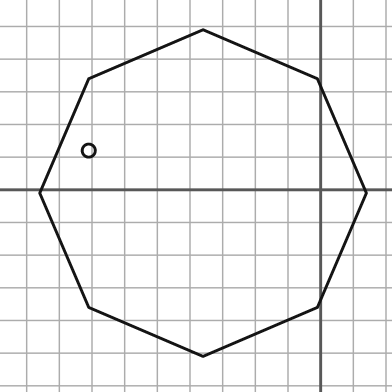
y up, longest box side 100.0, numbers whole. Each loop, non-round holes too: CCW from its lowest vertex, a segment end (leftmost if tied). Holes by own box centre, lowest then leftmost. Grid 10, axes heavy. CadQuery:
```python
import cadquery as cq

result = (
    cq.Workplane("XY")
    .moveTo(-36.0, -51.0)
    .lineTo(-1.0, -36.0)
    .lineTo(14.0, -1.0)
    .lineTo(-1.0, 34.0)
    .lineTo(-36.0, 49.0)
    .lineTo(-71.0, 34.0)
    .lineTo(-86.0, -1.0)
    .lineTo(-71.0, -36.0)
    .close()
    .moveTo(-71.0, 12.0)
    .circle(2.0)
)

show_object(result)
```